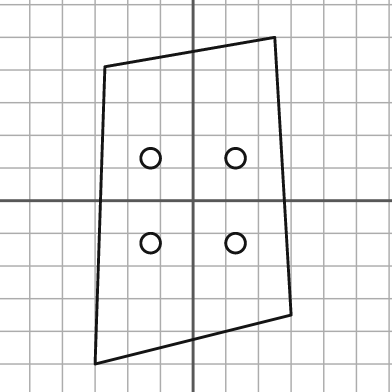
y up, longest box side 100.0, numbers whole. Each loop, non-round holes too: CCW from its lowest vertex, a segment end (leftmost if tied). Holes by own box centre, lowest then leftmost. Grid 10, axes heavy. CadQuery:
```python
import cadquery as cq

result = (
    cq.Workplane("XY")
    .moveTo(-30.0, -50.0)
    .lineTo(30.0, -35.0)
    .lineTo(25.0, 50.0)
    .lineTo(-27.0, 41.0)
    .close()
    .moveTo(-13.0, -13.0)
    .circle(3.0)
    .moveTo(13.0, -13.0)
    .circle(3.0)
    .moveTo(-13.0, 13.0)
    .circle(3.0)
    .moveTo(13.0, 13.0)
    .circle(3.0)
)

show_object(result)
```